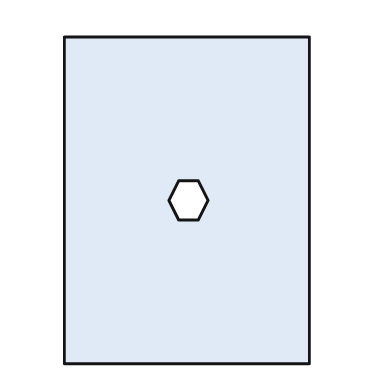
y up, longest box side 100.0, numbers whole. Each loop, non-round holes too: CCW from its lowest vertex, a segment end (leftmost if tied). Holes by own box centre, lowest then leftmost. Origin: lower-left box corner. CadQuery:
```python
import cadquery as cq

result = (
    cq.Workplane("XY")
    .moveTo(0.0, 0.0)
    .lineTo(75.0, 0.0)
    .lineTo(75.0, 100.0)
    .lineTo(0.0, 100.0)
    .close()
    .moveTo(35.0, 44.0)
    .lineTo(41.0, 44.0)
    .lineTo(44.0, 50.0)
    .lineTo(41.0, 56.0)
    .lineTo(35.0, 56.0)
    .lineTo(32.0, 50.0)
    .close()
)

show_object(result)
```